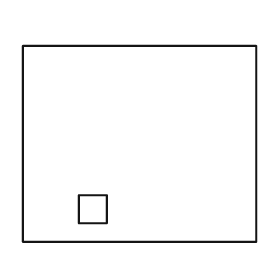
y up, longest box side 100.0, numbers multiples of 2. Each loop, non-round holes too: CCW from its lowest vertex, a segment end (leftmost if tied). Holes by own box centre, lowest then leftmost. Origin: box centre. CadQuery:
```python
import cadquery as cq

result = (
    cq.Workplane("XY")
    .moveTo(-50.0, -42.0)
    .lineTo(50.0, -42.0)
    .lineTo(50.0, 42.0)
    .lineTo(-50.0, 42.0)
    .close()
    .moveTo(-26.0, -34.0)
    .lineTo(-14.0, -34.0)
    .lineTo(-14.0, -22.0)
    .lineTo(-26.0, -22.0)
    .close()
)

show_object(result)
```